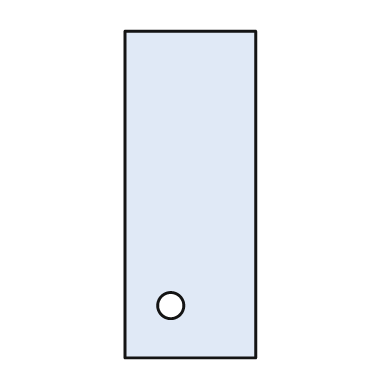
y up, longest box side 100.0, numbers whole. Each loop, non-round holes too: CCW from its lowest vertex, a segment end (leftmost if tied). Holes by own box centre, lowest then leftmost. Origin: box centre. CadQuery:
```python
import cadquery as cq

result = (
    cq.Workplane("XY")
    .moveTo(-20.0, -50.0)
    .lineTo(20.0, -50.0)
    .lineTo(20.0, 50.0)
    .lineTo(-20.0, 50.0)
    .close()
    .moveTo(-6.0, -34.0)
    .circle(4.0)
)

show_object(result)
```